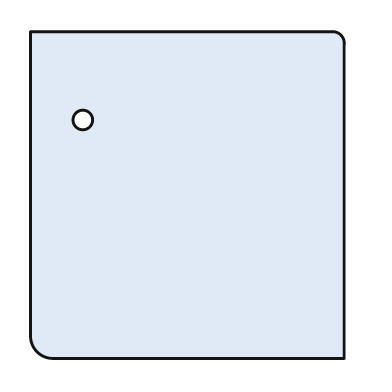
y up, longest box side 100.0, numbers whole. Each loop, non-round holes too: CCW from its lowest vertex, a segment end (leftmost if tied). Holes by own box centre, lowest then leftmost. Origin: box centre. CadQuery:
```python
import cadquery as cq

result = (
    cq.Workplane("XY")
    .moveTo(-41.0, -50.0)
    .lineTo(48.0, -50.0)
    .lineTo(48.0, 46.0)
    .threePointArc((47.0, 49.0), (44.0, 50.0))
    .lineTo(-48.0, 50.0)
    .lineTo(-48.0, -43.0)
    .threePointArc((-46.0, -48.0), (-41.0, -50.0))
    .close()
    .moveTo(-32.0, 23.0)
    .circle(3.0)
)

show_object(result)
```